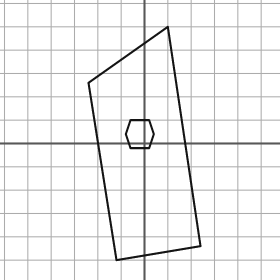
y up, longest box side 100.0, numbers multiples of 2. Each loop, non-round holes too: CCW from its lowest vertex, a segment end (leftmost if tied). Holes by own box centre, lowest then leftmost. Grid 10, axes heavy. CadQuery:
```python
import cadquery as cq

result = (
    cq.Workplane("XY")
    .moveTo(-12.0, -50.0)
    .lineTo(24.0, -44.0)
    .lineTo(10.0, 50.0)
    .lineTo(-24.0, 26.0)
    .close()
    .moveTo(-6.0, -2.0)
    .lineTo(2.0, -2.0)
    .lineTo(4.0, 4.0)
    .lineTo(2.0, 10.0)
    .lineTo(-6.0, 10.0)
    .lineTo(-8.0, 4.0)
    .close()
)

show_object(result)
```